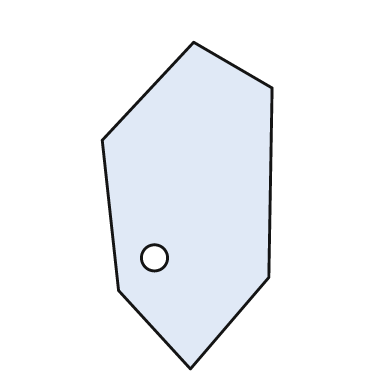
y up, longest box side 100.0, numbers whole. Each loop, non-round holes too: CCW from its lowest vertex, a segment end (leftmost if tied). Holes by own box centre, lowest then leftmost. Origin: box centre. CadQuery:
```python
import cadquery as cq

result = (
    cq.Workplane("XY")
    .moveTo(1.0, -50.0)
    .lineTo(25.0, -22.0)
    .lineTo(26.0, 36.0)
    .lineTo(2.0, 50.0)
    .lineTo(-26.0, 20.0)
    .lineTo(-21.0, -26.0)
    .close()
    .moveTo(-10.0, -16.0)
    .circle(4.0)
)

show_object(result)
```